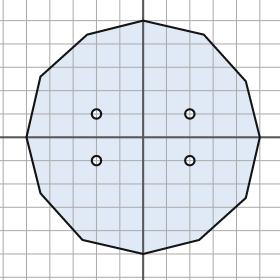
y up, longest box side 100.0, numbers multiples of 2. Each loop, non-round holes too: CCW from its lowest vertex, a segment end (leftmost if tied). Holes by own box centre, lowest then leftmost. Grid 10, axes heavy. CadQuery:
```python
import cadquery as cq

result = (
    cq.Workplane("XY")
    .moveTo(0.0, -50.0)
    .lineTo(24.0, -44.0)
    .lineTo(44.0, -26.0)
    .lineTo(50.0, 0.0)
    .lineTo(44.0, 24.0)
    .lineTo(26.0, 44.0)
    .lineTo(0.0, 50.0)
    .lineTo(-24.0, 44.0)
    .lineTo(-44.0, 26.0)
    .lineTo(-50.0, 0.0)
    .lineTo(-44.0, -24.0)
    .lineTo(-26.0, -44.0)
    .close()
    .moveTo(-20.0, -10.0)
    .circle(2.0)
    .moveTo(20.0, -10.0)
    .circle(2.0)
    .moveTo(-20.0, 10.0)
    .circle(2.0)
    .moveTo(20.0, 10.0)
    .circle(2.0)
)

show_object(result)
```